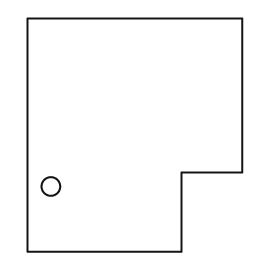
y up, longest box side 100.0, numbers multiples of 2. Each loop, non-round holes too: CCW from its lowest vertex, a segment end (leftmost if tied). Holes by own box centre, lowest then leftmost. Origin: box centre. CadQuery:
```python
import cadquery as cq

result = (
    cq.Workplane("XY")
    .moveTo(-46.0, -50.0)
    .lineTo(20.0, -50.0)
    .lineTo(20.0, -16.0)
    .lineTo(46.0, -16.0)
    .lineTo(46.0, 50.0)
    .lineTo(-46.0, 50.0)
    .close()
    .moveTo(-36.0, -22.0)
    .circle(4.0)
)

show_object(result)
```